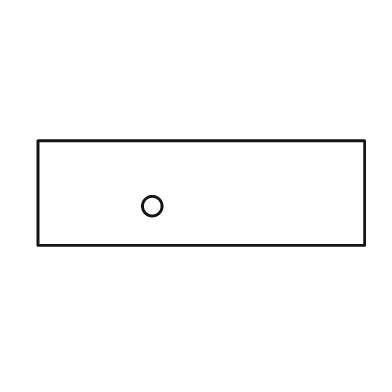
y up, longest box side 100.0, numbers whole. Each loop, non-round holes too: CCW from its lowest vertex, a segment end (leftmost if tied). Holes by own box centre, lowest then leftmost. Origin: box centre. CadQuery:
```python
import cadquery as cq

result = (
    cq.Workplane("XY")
    .moveTo(-50.0, -16.0)
    .lineTo(50.0, -16.0)
    .lineTo(50.0, 16.0)
    .lineTo(-50.0, 16.0)
    .close()
    .moveTo(-15.0, -4.0)
    .circle(3.0)
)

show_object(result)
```